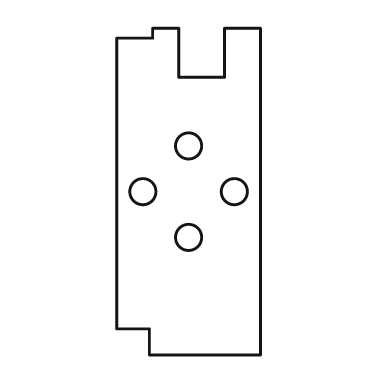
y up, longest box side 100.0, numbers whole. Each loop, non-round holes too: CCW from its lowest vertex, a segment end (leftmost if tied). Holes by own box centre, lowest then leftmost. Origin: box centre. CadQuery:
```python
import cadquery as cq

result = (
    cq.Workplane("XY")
    .moveTo(-12.0, -50.0)
    .lineTo(22.0, -50.0)
    .lineTo(22.0, 50.0)
    .lineTo(11.0, 50.0)
    .lineTo(11.0, 35.0)
    .lineTo(-3.0, 35.0)
    .lineTo(-3.0, 50.0)
    .lineTo(-11.0, 50.0)
    .lineTo(-11.0, 47.0)
    .lineTo(-22.0, 47.0)
    .lineTo(-22.0, -42.0)
    .lineTo(-12.0, -42.0)
    .close()
    .moveTo(0.0, -14.0)
    .circle(4.0)
    .moveTo(-14.0, 0.0)
    .circle(4.0)
    .moveTo(14.0, 0.0)
    .circle(4.0)
    .moveTo(0.0, 14.0)
    .circle(4.0)
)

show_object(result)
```